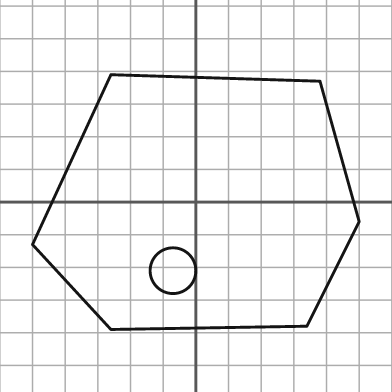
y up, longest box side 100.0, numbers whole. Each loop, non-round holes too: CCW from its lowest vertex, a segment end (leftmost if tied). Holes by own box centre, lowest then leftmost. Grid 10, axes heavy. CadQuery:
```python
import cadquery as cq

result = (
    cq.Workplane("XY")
    .moveTo(-26.0, -39.0)
    .lineTo(34.0, -38.0)
    .lineTo(50.0, -6.0)
    .lineTo(38.0, 37.0)
    .lineTo(-26.0, 39.0)
    .lineTo(-50.0, -13.0)
    .close()
    .moveTo(-7.0, -21.0)
    .circle(7.0)
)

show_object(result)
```